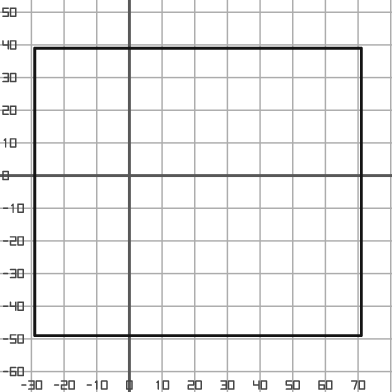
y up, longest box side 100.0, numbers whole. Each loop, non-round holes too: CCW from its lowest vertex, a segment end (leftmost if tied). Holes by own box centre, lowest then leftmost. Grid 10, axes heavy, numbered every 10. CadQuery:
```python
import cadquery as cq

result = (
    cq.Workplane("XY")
    .moveTo(-29.0, -49.0)
    .lineTo(71.0, -49.0)
    .lineTo(71.0, 39.0)
    .lineTo(-29.0, 39.0)
    .close()
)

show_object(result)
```